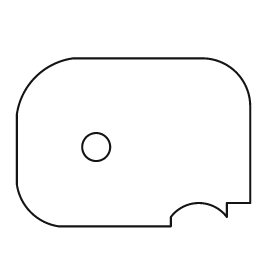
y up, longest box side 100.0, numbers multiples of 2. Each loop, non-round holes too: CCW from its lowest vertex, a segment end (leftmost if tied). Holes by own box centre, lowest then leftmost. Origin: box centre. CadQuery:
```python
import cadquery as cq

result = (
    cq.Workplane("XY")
    .moveTo(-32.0, -36.0)
    .lineTo(16.0, -36.0)
    .lineTo(16.0, -32.0)
    .threePointArc((28.0, -26.0), (40.0, -32.0))
    .lineTo(40.0, -26.0)
    .lineTo(50.0, -26.0)
    .lineTo(50.0, 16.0)
    .threePointArc((44.0, 30.0), (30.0, 36.0))
    .lineTo(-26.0, 36.0)
    .threePointArc((-42.0, 28.0), (-50.0, 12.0))
    .lineTo(-50.0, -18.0)
    .threePointArc((-44.0, -30.0), (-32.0, -36.0))
    .close()
    .moveTo(-16.0, -2.0)
    .circle(6.0)
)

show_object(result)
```